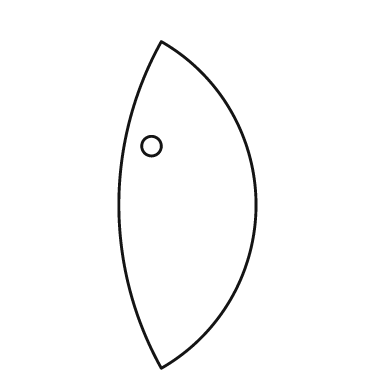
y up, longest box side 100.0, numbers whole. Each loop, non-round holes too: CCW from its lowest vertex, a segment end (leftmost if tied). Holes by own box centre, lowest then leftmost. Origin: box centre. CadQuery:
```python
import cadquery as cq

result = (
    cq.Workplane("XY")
    .moveTo(-8.0, -50.0)
    .threePointArc((21.0, 0.0), (-8.0, 50.0))
    .threePointArc((-21.0, 0.0), (-8.0, -50.0))
    .close()
    .moveTo(-11.0, 18.0)
    .circle(3.0)
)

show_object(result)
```